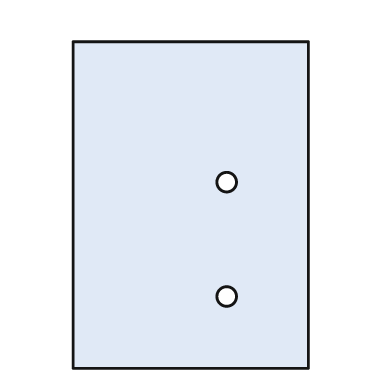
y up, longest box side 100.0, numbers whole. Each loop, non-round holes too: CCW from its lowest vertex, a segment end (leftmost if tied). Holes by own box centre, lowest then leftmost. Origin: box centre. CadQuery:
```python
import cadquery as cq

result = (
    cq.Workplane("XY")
    .moveTo(-36.0, -50.0)
    .lineTo(36.0, -50.0)
    .lineTo(36.0, 50.0)
    .lineTo(-36.0, 50.0)
    .close()
    .moveTo(11.0, -28.0)
    .circle(3.0)
    .moveTo(11.0, 7.0)
    .circle(3.0)
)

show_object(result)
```